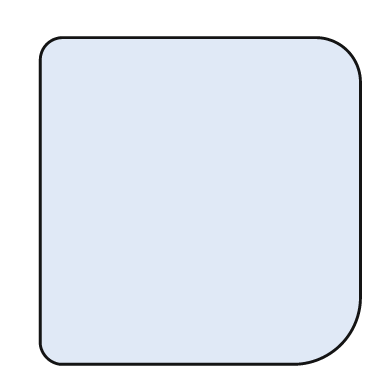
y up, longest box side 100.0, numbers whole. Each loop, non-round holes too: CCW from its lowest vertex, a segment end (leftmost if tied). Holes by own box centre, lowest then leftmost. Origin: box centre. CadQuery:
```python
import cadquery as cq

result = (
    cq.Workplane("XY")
    .moveTo(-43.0, -50.0)
    .lineTo(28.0, -50.0)
    .threePointArc((43.0, -44.0), (49.0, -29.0))
    .lineTo(49.0, 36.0)
    .threePointArc((45.0, 46.0), (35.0, 50.0))
    .lineTo(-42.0, 50.0)
    .threePointArc((-47.0, 48.0), (-49.0, 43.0))
    .lineTo(-49.0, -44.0)
    .threePointArc((-47.0, -48.0), (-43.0, -50.0))
    .close()
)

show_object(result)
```